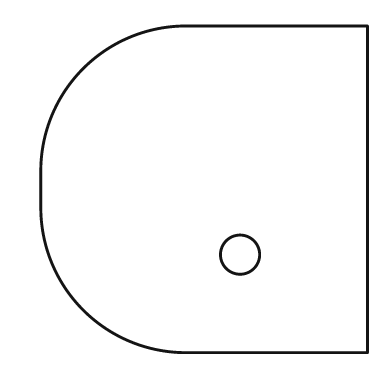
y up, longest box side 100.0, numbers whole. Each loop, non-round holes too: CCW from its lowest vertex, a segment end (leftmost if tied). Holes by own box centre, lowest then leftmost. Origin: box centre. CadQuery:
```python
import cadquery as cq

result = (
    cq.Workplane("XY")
    .moveTo(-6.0, -50.0)
    .lineTo(50.0, -50.0)
    .lineTo(50.0, 50.0)
    .lineTo(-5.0, 50.0)
    .threePointArc((-37.0, 37.0), (-50.0, 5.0))
    .lineTo(-50.0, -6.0)
    .threePointArc((-37.0, -37.0), (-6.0, -50.0))
    .close()
    .moveTo(11.0, -20.0)
    .circle(6.0)
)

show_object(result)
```